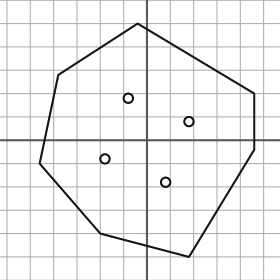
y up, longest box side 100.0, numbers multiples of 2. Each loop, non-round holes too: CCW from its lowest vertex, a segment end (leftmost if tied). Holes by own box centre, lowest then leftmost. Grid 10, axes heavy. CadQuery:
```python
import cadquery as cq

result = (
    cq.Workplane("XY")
    .moveTo(18.0, -50.0)
    .lineTo(46.0, -4.0)
    .lineTo(46.0, 20.0)
    .lineTo(-4.0, 50.0)
    .lineTo(-38.0, 28.0)
    .lineTo(-46.0, -10.0)
    .lineTo(-20.0, -40.0)
    .close()
    .moveTo(8.0, -18.0)
    .circle(2.0)
    .moveTo(-18.0, -8.0)
    .circle(2.0)
    .moveTo(18.0, 8.0)
    .circle(2.0)
    .moveTo(-8.0, 18.0)
    .circle(2.0)
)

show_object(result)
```